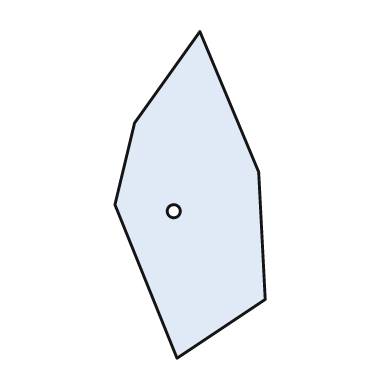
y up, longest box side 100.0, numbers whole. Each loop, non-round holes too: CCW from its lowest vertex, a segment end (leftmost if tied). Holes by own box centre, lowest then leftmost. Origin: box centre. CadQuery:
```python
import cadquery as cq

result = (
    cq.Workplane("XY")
    .moveTo(-4.0, -50.0)
    .lineTo(23.0, -32.0)
    .lineTo(21.0, 7.0)
    .lineTo(3.0, 50.0)
    .lineTo(-17.0, 22.0)
    .lineTo(-23.0, -3.0)
    .close()
    .moveTo(-5.0, -5.0)
    .circle(2.0)
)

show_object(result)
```